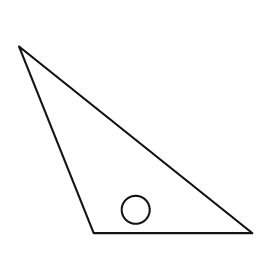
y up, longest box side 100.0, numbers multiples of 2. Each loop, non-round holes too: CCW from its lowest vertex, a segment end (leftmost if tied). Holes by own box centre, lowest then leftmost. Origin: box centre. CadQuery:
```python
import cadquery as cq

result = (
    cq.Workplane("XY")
    .moveTo(-18.0, -40.0)
    .lineTo(50.0, -40.0)
    .lineTo(-50.0, 40.0)
    .close()
    .moveTo(0.0, -30.0)
    .circle(6.0)
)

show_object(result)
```